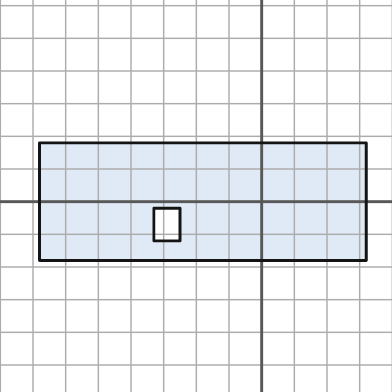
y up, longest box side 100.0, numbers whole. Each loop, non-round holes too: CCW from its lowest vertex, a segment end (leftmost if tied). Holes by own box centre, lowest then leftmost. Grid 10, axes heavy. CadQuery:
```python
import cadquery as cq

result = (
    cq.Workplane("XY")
    .moveTo(-68.0, -18.0)
    .lineTo(32.0, -18.0)
    .lineTo(32.0, 18.0)
    .lineTo(-68.0, 18.0)
    .close()
    .moveTo(-33.0, -12.0)
    .lineTo(-25.0, -12.0)
    .lineTo(-25.0, -2.0)
    .lineTo(-33.0, -2.0)
    .close()
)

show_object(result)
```